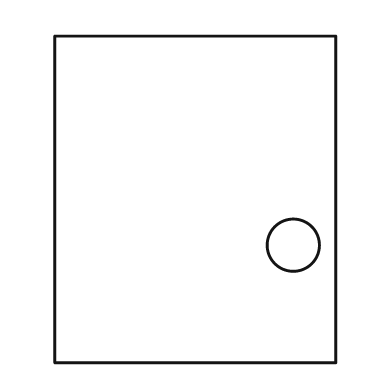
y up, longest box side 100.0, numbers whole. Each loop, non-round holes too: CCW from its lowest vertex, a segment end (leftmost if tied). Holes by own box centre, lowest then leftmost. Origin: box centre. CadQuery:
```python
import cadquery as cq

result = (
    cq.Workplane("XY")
    .moveTo(-43.0, -50.0)
    .lineTo(43.0, -50.0)
    .lineTo(43.0, 50.0)
    .lineTo(-43.0, 50.0)
    .close()
    .moveTo(30.0, -14.0)
    .circle(8.0)
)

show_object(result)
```